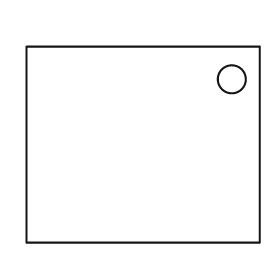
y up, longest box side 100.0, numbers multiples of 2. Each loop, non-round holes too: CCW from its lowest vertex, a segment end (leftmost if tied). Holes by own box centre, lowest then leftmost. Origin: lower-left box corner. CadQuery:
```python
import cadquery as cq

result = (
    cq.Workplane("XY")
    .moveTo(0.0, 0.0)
    .lineTo(100.0, 0.0)
    .lineTo(100.0, 84.0)
    .lineTo(0.0, 84.0)
    .close()
    .moveTo(88.0, 70.0)
    .circle(6.0)
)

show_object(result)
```